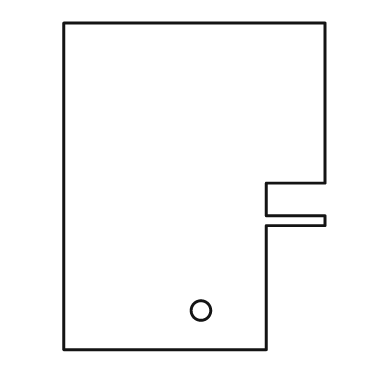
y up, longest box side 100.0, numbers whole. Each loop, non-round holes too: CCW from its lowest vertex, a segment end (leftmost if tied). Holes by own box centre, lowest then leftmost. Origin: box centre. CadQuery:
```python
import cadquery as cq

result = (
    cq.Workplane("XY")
    .moveTo(-40.0, -50.0)
    .lineTo(22.0, -50.0)
    .lineTo(22.0, -12.0)
    .lineTo(40.0, -12.0)
    .lineTo(40.0, -9.0)
    .lineTo(22.0, -9.0)
    .lineTo(22.0, 1.0)
    .lineTo(40.0, 1.0)
    .lineTo(40.0, 50.0)
    .lineTo(-40.0, 50.0)
    .close()
    .moveTo(2.0, -38.0)
    .circle(3.0)
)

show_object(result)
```